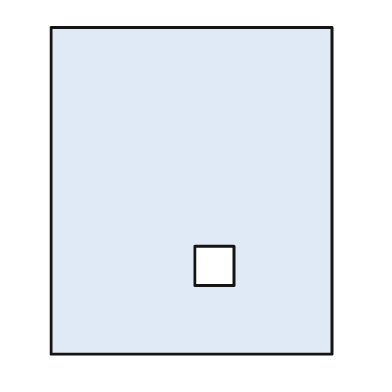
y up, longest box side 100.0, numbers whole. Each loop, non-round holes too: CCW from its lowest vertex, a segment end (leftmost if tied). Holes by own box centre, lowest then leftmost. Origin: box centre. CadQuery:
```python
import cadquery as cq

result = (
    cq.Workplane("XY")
    .moveTo(-43.0, -50.0)
    .lineTo(43.0, -50.0)
    .lineTo(43.0, 50.0)
    .lineTo(-43.0, 50.0)
    .close()
    .moveTo(1.0, -29.0)
    .lineTo(13.0, -29.0)
    .lineTo(13.0, -17.0)
    .lineTo(1.0, -17.0)
    .close()
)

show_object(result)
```